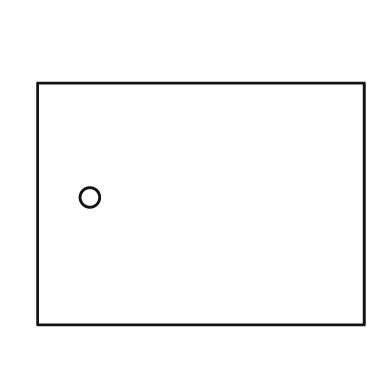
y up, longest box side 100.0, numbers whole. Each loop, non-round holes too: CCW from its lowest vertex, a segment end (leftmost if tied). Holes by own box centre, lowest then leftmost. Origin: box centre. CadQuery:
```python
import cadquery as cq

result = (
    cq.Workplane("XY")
    .moveTo(-50.0, -37.0)
    .lineTo(50.0, -37.0)
    .lineTo(50.0, 37.0)
    .lineTo(-50.0, 37.0)
    .close()
    .moveTo(-34.0, 2.0)
    .circle(3.0)
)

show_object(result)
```